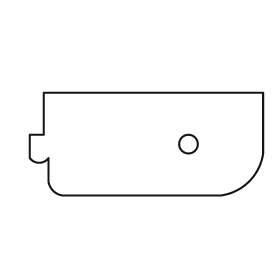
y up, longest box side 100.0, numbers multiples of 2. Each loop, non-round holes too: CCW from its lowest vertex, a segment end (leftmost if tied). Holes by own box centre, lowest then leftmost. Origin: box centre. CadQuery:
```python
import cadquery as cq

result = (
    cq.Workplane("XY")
    .moveTo(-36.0, -22.0)
    .lineTo(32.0, -22.0)
    .threePointArc((44.0, -16.0), (50.0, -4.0))
    .lineTo(50.0, 22.0)
    .lineTo(-44.0, 22.0)
    .lineTo(-44.0, 4.0)
    .lineTo(-50.0, 4.0)
    .lineTo(-50.0, -6.0)
    .threePointArc((-46.0, -8.0), (-42.0, -6.0))
    .lineTo(-42.0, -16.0)
    .threePointArc((-40.0, -20.0), (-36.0, -22.0))
    .close()
    .moveTo(18.0, 0.0)
    .circle(4.0)
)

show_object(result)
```